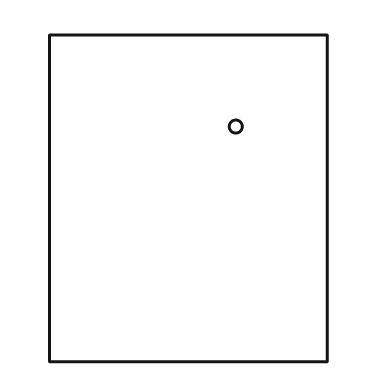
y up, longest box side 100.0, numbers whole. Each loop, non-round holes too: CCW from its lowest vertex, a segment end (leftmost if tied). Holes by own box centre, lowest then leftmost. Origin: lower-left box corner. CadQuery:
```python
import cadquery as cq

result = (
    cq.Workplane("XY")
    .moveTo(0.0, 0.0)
    .lineTo(85.0, 0.0)
    .lineTo(85.0, 100.0)
    .lineTo(0.0, 100.0)
    .close()
    .moveTo(57.0, 72.0)
    .circle(2.0)
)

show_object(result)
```